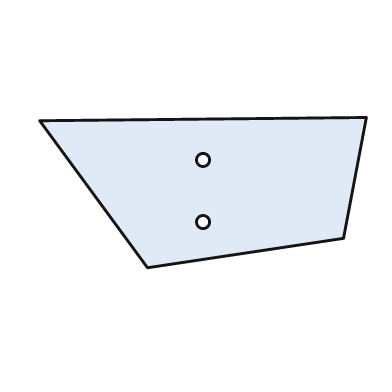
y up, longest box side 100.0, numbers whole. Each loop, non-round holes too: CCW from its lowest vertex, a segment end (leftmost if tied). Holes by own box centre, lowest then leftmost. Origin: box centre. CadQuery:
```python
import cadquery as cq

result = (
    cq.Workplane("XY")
    .moveTo(-17.0, -23.0)
    .lineTo(43.0, -14.0)
    .lineTo(50.0, 23.0)
    .lineTo(-50.0, 22.0)
    .close()
    .moveTo(0.0, -9.0)
    .circle(2.0)
    .moveTo(0.0, 10.0)
    .circle(2.0)
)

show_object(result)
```